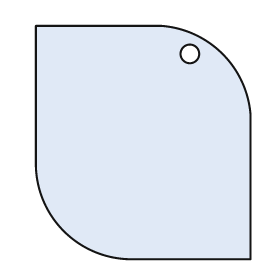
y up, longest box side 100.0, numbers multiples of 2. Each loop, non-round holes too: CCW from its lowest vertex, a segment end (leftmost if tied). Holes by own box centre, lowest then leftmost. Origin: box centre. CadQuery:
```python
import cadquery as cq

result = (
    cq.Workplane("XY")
    .moveTo(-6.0, -50.0)
    .lineTo(46.0, -50.0)
    .lineTo(46.0, 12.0)
    .threePointArc((34.0, 38.0), (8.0, 50.0))
    .lineTo(-46.0, 50.0)
    .lineTo(-46.0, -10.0)
    .threePointArc((-34.0, -38.0), (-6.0, -50.0))
    .close()
    .moveTo(20.0, 38.0)
    .circle(4.0)
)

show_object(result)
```